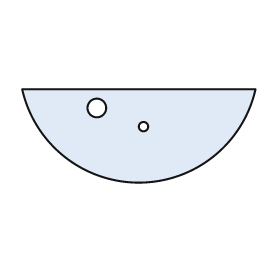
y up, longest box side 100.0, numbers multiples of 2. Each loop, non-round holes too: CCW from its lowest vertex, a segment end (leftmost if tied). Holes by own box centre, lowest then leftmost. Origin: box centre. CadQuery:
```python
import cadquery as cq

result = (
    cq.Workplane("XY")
    .moveTo(-50.0, 20.0)
    .threePointArc((0.0, -20.0), (50.0, 20.0))
    .close()
    .moveTo(2.0, 4.0)
    .circle(2.0)
    .moveTo(-18.0, 12.0)
    .circle(4.0)
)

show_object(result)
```